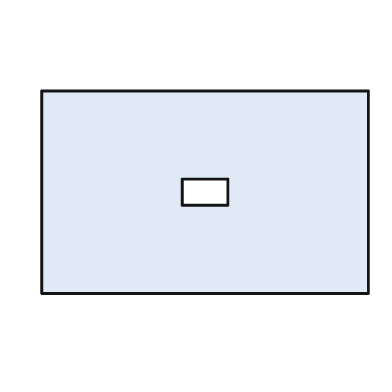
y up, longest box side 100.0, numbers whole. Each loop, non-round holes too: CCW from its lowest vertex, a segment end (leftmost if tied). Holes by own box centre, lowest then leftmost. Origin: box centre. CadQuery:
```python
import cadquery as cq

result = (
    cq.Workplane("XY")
    .moveTo(-50.0, -31.0)
    .lineTo(50.0, -31.0)
    .lineTo(50.0, 31.0)
    .lineTo(-50.0, 31.0)
    .close()
    .moveTo(-7.0, -4.0)
    .lineTo(7.0, -4.0)
    .lineTo(7.0, 4.0)
    .lineTo(-7.0, 4.0)
    .close()
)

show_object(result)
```